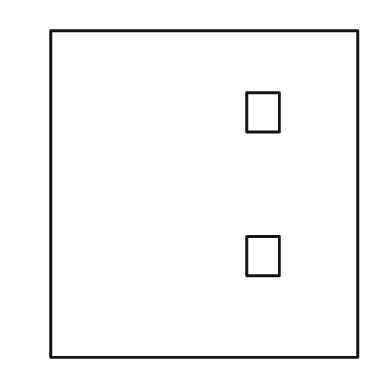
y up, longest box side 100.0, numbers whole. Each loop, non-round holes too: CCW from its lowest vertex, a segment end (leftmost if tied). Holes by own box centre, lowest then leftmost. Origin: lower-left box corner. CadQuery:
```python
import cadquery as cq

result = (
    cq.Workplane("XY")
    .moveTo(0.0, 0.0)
    .lineTo(94.0, 0.0)
    .lineTo(94.0, 100.0)
    .lineTo(0.0, 100.0)
    .close()
    .moveTo(60.0, 25.0)
    .lineTo(70.0, 25.0)
    .lineTo(70.0, 37.0)
    .lineTo(60.0, 37.0)
    .close()
    .moveTo(60.0, 69.0)
    .lineTo(70.0, 69.0)
    .lineTo(70.0, 81.0)
    .lineTo(60.0, 81.0)
    .close()
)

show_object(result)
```